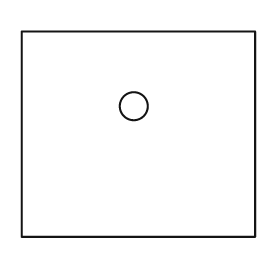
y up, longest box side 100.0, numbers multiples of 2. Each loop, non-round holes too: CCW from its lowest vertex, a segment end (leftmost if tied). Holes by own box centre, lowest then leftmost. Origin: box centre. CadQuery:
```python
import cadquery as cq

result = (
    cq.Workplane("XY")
    .moveTo(-50.0, -44.0)
    .lineTo(50.0, -44.0)
    .lineTo(50.0, 44.0)
    .lineTo(-50.0, 44.0)
    .close()
    .moveTo(-2.0, 12.0)
    .circle(6.0)
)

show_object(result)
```